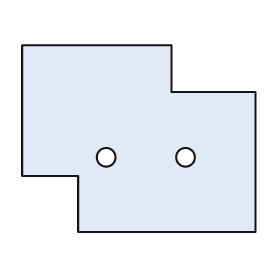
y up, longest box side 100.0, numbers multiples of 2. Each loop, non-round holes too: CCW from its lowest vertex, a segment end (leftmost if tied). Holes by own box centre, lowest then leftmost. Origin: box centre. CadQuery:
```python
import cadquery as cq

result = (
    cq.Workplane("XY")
    .moveTo(-26.0, -40.0)
    .lineTo(50.0, -40.0)
    .lineTo(50.0, 20.0)
    .lineTo(14.0, 20.0)
    .lineTo(14.0, 40.0)
    .lineTo(-50.0, 40.0)
    .lineTo(-50.0, -16.0)
    .lineTo(-26.0, -16.0)
    .close()
    .moveTo(-14.0, -8.0)
    .circle(4.0)
    .moveTo(20.0, -8.0)
    .circle(4.0)
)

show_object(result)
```